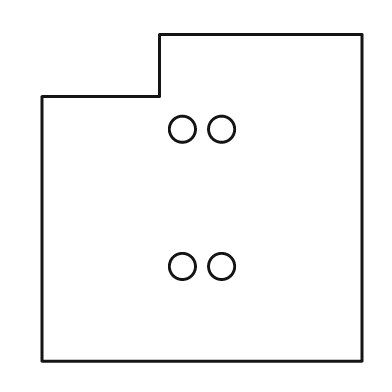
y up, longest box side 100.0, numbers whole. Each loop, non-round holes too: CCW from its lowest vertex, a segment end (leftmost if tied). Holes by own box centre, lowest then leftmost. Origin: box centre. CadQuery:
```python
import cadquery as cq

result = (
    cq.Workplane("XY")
    .moveTo(-49.0, -50.0)
    .lineTo(49.0, -50.0)
    .lineTo(49.0, 50.0)
    .lineTo(-13.0, 50.0)
    .lineTo(-13.0, 31.0)
    .lineTo(-49.0, 31.0)
    .close()
    .moveTo(-6.0, -21.0)
    .circle(4.0)
    .moveTo(6.0, -21.0)
    .circle(4.0)
    .moveTo(-6.0, 21.0)
    .circle(4.0)
    .moveTo(6.0, 21.0)
    .circle(4.0)
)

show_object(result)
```